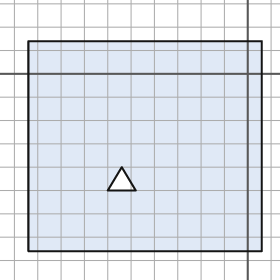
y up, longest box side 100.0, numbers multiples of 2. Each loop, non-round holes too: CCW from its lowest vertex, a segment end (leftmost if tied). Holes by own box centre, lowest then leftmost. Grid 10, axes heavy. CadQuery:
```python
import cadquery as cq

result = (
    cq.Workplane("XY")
    .moveTo(-94.0, -76.0)
    .lineTo(6.0, -76.0)
    .lineTo(6.0, 14.0)
    .lineTo(-94.0, 14.0)
    .close()
    .moveTo(-60.0, -50.0)
    .lineTo(-48.0, -50.0)
    .lineTo(-54.0, -40.0)
    .close()
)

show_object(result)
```